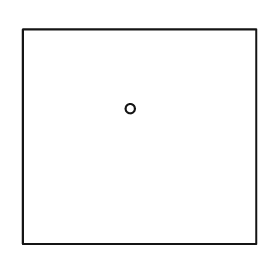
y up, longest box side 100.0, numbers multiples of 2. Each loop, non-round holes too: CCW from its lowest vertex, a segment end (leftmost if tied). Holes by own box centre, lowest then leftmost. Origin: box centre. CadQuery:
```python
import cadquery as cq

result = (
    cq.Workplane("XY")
    .moveTo(-50.0, -46.0)
    .lineTo(50.0, -46.0)
    .lineTo(50.0, 46.0)
    .lineTo(-50.0, 46.0)
    .close()
    .moveTo(-4.0, 12.0)
    .circle(2.0)
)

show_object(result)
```